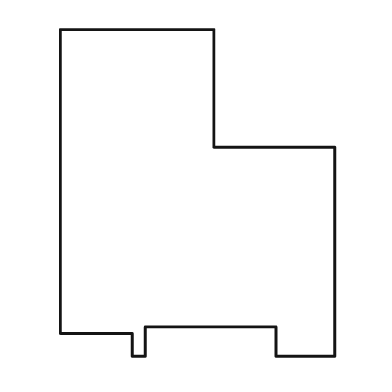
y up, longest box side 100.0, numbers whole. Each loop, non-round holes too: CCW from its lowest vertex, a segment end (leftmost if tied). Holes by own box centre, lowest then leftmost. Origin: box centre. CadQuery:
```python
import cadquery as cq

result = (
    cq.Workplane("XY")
    .moveTo(-20.0, -50.0)
    .lineTo(-16.0, -50.0)
    .lineTo(-16.0, -41.0)
    .lineTo(24.0, -41.0)
    .lineTo(24.0, -50.0)
    .lineTo(42.0, -50.0)
    .lineTo(42.0, 14.0)
    .lineTo(5.0, 14.0)
    .lineTo(5.0, 50.0)
    .lineTo(-42.0, 50.0)
    .lineTo(-42.0, -43.0)
    .lineTo(-20.0, -43.0)
    .close()
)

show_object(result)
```